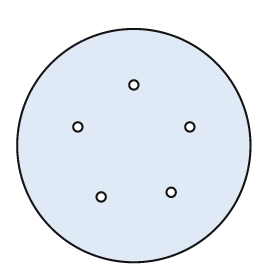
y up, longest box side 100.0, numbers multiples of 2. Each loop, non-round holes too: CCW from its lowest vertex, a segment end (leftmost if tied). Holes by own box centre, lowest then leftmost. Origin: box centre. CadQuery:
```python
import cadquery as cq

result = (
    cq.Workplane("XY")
    .moveTo(0.0, 0.0)
    .circle(50.0)
    .moveTo(-14.0, -22.0)
    .circle(2.0)
    .moveTo(16.0, -20.0)
    .circle(2.0)
    .moveTo(-24.0, 8.0)
    .circle(2.0)
    .moveTo(24.0, 8.0)
    .circle(2.0)
    .moveTo(0.0, 26.0)
    .circle(2.0)
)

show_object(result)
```